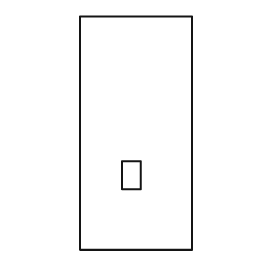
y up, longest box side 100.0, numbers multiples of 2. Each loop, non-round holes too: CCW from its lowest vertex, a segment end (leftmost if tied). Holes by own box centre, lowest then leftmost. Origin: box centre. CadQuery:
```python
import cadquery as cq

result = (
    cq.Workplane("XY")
    .moveTo(-24.0, -50.0)
    .lineTo(24.0, -50.0)
    .lineTo(24.0, 50.0)
    .lineTo(-24.0, 50.0)
    .close()
    .moveTo(-6.0, -24.0)
    .lineTo(2.0, -24.0)
    .lineTo(2.0, -12.0)
    .lineTo(-6.0, -12.0)
    .close()
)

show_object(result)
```